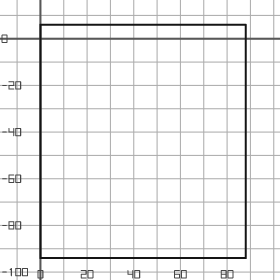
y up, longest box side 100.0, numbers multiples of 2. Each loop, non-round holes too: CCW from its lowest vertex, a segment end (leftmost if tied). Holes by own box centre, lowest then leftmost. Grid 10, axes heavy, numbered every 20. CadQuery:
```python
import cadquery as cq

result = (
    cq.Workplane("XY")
    .moveTo(0.0, -94.0)
    .lineTo(88.0, -94.0)
    .lineTo(88.0, 6.0)
    .lineTo(0.0, 6.0)
    .close()
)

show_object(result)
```